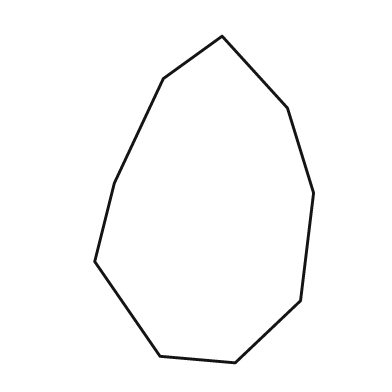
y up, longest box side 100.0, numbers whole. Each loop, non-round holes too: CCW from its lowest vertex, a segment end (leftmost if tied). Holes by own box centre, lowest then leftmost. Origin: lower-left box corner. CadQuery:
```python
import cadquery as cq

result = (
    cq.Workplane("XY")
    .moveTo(43.0, 0.0)
    .lineTo(63.0, 19.0)
    .lineTo(67.0, 52.0)
    .lineTo(59.0, 78.0)
    .lineTo(39.0, 100.0)
    .lineTo(21.0, 87.0)
    .lineTo(6.0, 55.0)
    .lineTo(0.0, 31.0)
    .lineTo(20.0, 2.0)
    .close()
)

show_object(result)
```